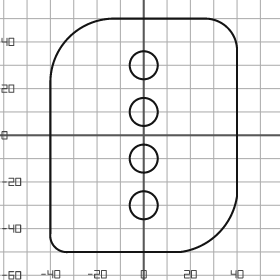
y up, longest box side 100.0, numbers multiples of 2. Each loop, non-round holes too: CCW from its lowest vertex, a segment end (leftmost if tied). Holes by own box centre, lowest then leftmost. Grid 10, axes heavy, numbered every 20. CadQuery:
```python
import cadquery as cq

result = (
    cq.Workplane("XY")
    .moveTo(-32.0, -50.0)
    .lineTo(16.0, -50.0)
    .threePointArc((32.0, -42.0), (40.0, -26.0))
    .lineTo(40.0, 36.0)
    .threePointArc((36.0, 46.0), (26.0, 50.0))
    .lineTo(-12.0, 50.0)
    .threePointArc((-32.0, 42.0), (-40.0, 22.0))
    .lineTo(-40.0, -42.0)
    .threePointArc((-38.0, -48.0), (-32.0, -50.0))
    .close()
    .moveTo(0.0, -30.0)
    .circle(6.0)
    .moveTo(0.0, -10.0)
    .circle(6.0)
    .moveTo(0.0, 10.0)
    .circle(6.0)
    .moveTo(0.0, 30.0)
    .circle(6.0)
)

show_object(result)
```